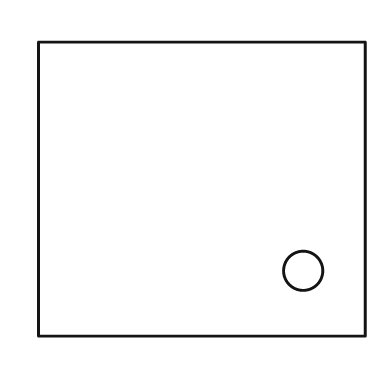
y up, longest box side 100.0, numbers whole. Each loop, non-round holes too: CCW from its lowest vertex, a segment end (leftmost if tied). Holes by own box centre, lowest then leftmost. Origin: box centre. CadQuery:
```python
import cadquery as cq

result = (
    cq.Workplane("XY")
    .moveTo(-50.0, -45.0)
    .lineTo(50.0, -45.0)
    .lineTo(50.0, 45.0)
    .lineTo(-50.0, 45.0)
    .close()
    .moveTo(31.0, -25.0)
    .circle(6.0)
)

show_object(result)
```